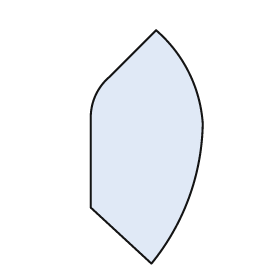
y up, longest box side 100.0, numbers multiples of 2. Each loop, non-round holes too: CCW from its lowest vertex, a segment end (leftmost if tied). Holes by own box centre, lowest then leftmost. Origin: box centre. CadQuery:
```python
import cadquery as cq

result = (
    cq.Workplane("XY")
    .moveTo(2.0, -50.0)
    .threePointArc((18.0, -22.0), (24.0, 10.0))
    .threePointArc((18.0, 32.0), (4.0, 50.0))
    .lineTo(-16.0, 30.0)
    .threePointArc((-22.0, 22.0), (-24.0, 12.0))
    .lineTo(-24.0, -26.0)
    .close()
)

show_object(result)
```